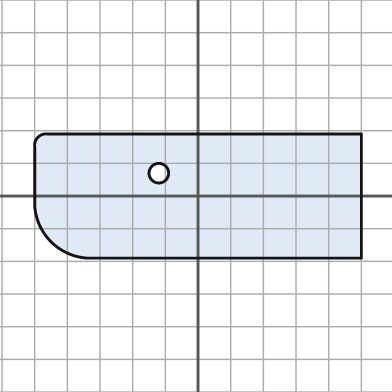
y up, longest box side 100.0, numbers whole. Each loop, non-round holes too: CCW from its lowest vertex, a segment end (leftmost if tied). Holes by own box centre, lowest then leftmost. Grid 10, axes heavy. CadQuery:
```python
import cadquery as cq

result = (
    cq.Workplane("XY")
    .moveTo(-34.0, -19.0)
    .lineTo(50.0, -19.0)
    .lineTo(50.0, 19.0)
    .lineTo(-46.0, 19.0)
    .threePointArc((-49.0, 18.0), (-50.0, 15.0))
    .lineTo(-50.0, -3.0)
    .threePointArc((-45.0, -14.0), (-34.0, -19.0))
    .close()
    .moveTo(-12.0, 7.0)
    .circle(3.0)
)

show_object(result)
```